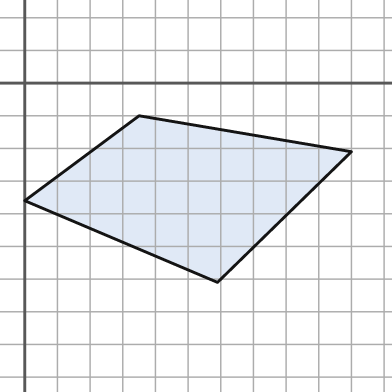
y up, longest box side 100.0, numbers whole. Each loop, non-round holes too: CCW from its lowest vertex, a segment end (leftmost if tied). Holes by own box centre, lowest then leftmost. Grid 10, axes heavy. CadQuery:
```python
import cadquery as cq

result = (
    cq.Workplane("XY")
    .moveTo(59.0, -61.0)
    .lineTo(100.0, -21.0)
    .lineTo(35.0, -10.0)
    .lineTo(0.0, -36.0)
    .close()
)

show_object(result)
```